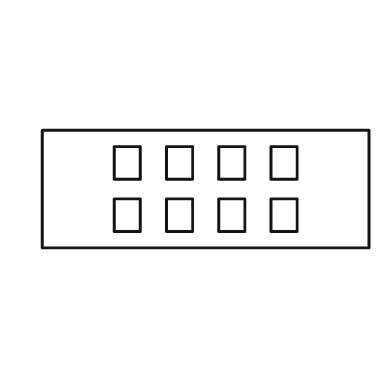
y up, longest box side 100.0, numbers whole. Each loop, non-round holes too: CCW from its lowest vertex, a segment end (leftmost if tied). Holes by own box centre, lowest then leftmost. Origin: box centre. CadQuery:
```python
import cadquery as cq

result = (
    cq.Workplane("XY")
    .moveTo(-50.0, -18.0)
    .lineTo(50.0, -18.0)
    .lineTo(50.0, 18.0)
    .lineTo(-50.0, 18.0)
    .close()
    .moveTo(-28.0, -13.0)
    .lineTo(-20.0, -13.0)
    .lineTo(-20.0, -3.0)
    .lineTo(-28.0, -3.0)
    .close()
    .moveTo(-12.0, -13.0)
    .lineTo(-4.0, -13.0)
    .lineTo(-4.0, -3.0)
    .lineTo(-12.0, -3.0)
    .close()
    .moveTo(4.0, -13.0)
    .lineTo(12.0, -13.0)
    .lineTo(12.0, -3.0)
    .lineTo(4.0, -3.0)
    .close()
    .moveTo(20.0, -13.0)
    .lineTo(28.0, -13.0)
    .lineTo(28.0, -3.0)
    .lineTo(20.0, -3.0)
    .close()
    .moveTo(-28.0, 3.0)
    .lineTo(-20.0, 3.0)
    .lineTo(-20.0, 13.0)
    .lineTo(-28.0, 13.0)
    .close()
    .moveTo(-12.0, 3.0)
    .lineTo(-4.0, 3.0)
    .lineTo(-4.0, 13.0)
    .lineTo(-12.0, 13.0)
    .close()
    .moveTo(4.0, 3.0)
    .lineTo(12.0, 3.0)
    .lineTo(12.0, 13.0)
    .lineTo(4.0, 13.0)
    .close()
    .moveTo(20.0, 3.0)
    .lineTo(28.0, 3.0)
    .lineTo(28.0, 13.0)
    .lineTo(20.0, 13.0)
    .close()
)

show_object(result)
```